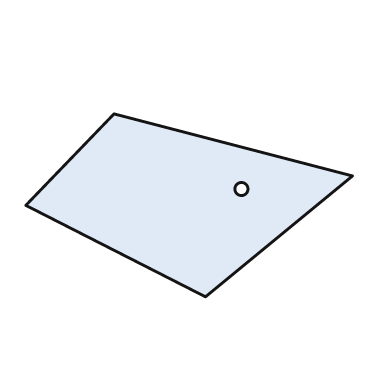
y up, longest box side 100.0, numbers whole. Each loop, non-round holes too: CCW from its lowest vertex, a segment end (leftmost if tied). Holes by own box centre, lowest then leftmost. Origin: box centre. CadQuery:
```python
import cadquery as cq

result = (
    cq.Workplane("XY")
    .moveTo(5.0, -28.0)
    .lineTo(50.0, 9.0)
    .lineTo(-23.0, 28.0)
    .lineTo(-50.0, 0.0)
    .close()
    .moveTo(16.0, 5.0)
    .circle(2.0)
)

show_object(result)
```